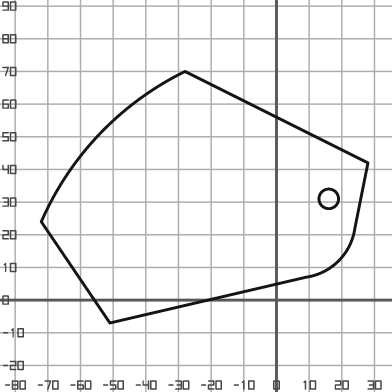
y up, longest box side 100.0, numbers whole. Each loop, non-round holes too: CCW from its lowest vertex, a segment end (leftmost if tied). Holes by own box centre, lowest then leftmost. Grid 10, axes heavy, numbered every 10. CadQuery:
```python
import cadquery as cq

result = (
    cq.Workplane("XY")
    .moveTo(-51.0, -7.0)
    .lineTo(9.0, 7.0)
    .threePointArc((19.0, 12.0), (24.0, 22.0))
    .lineTo(28.0, 42.0)
    .lineTo(-28.0, 70.0)
    .threePointArc((-54.0, 51.0), (-72.0, 24.0))
    .close()
    .moveTo(16.0, 31.0)
    .circle(3.0)
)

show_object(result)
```